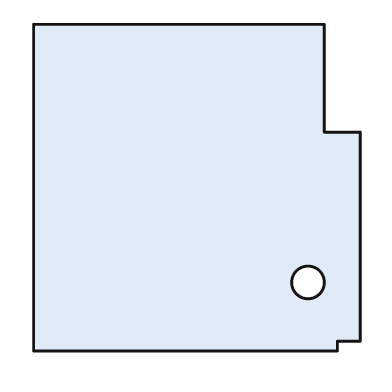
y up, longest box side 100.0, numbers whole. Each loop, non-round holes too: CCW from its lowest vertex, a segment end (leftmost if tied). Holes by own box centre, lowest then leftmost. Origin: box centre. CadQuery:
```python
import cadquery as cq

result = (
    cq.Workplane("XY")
    .moveTo(-50.0, -50.0)
    .lineTo(43.0, -50.0)
    .lineTo(43.0, -47.0)
    .lineTo(50.0, -47.0)
    .lineTo(50.0, 17.0)
    .lineTo(39.0, 17.0)
    .lineTo(39.0, 50.0)
    .lineTo(-50.0, 50.0)
    .close()
    .moveTo(34.0, -29.0)
    .circle(5.0)
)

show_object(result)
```